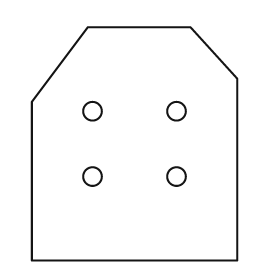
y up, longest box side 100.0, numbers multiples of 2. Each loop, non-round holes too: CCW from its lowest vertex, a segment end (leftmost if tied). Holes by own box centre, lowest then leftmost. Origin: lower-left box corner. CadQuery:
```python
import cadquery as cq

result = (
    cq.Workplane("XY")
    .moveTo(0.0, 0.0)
    .lineTo(88.0, 0.0)
    .lineTo(88.0, 78.0)
    .lineTo(68.0, 100.0)
    .lineTo(24.0, 100.0)
    .lineTo(0.0, 68.0)
    .close()
    .moveTo(26.0, 36.0)
    .circle(4.0)
    .moveTo(62.0, 36.0)
    .circle(4.0)
    .moveTo(26.0, 64.0)
    .circle(4.0)
    .moveTo(62.0, 64.0)
    .circle(4.0)
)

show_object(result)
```